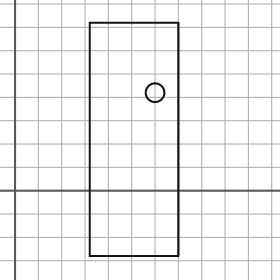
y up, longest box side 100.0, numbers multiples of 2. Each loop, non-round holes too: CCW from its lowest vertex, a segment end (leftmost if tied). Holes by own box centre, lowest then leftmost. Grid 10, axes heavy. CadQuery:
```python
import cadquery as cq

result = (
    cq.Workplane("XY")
    .moveTo(32.0, -28.0)
    .lineTo(70.0, -28.0)
    .lineTo(70.0, 72.0)
    .lineTo(32.0, 72.0)
    .close()
    .moveTo(60.0, 42.0)
    .circle(4.0)
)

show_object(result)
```